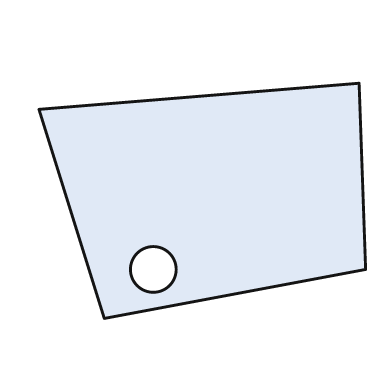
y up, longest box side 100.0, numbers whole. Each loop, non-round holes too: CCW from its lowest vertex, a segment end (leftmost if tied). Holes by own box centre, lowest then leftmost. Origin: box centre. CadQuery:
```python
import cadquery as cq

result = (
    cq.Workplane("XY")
    .moveTo(-30.0, -36.0)
    .lineTo(50.0, -21.0)
    .lineTo(48.0, 36.0)
    .lineTo(-50.0, 28.0)
    .close()
    .moveTo(-15.0, -21.0)
    .circle(7.0)
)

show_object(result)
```